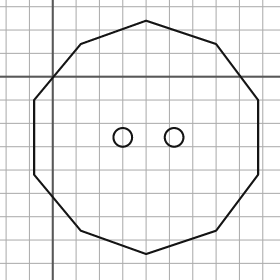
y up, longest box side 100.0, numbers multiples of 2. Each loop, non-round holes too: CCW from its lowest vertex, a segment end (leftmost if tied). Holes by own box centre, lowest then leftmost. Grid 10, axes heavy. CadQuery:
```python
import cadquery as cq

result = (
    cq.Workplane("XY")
    .moveTo(40.0, -76.0)
    .lineTo(70.0, -66.0)
    .lineTo(88.0, -42.0)
    .lineTo(88.0, -10.0)
    .lineTo(70.0, 14.0)
    .lineTo(40.0, 24.0)
    .lineTo(12.0, 14.0)
    .lineTo(-8.0, -10.0)
    .lineTo(-8.0, -42.0)
    .lineTo(12.0, -66.0)
    .close()
    .moveTo(30.0, -26.0)
    .circle(4.0)
    .moveTo(52.0, -26.0)
    .circle(4.0)
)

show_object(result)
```